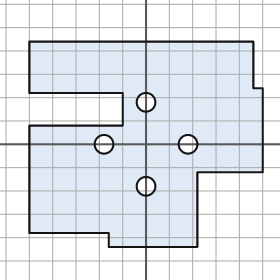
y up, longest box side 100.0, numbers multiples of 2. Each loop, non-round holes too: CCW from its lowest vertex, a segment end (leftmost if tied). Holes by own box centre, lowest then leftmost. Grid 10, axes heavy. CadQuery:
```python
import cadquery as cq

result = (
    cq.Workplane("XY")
    .moveTo(-16.0, -44.0)
    .lineTo(22.0, -44.0)
    .lineTo(22.0, -12.0)
    .lineTo(50.0, -12.0)
    .lineTo(50.0, 24.0)
    .lineTo(46.0, 24.0)
    .lineTo(46.0, 44.0)
    .lineTo(-50.0, 44.0)
    .lineTo(-50.0, 22.0)
    .lineTo(-10.0, 22.0)
    .lineTo(-10.0, 8.0)
    .lineTo(-50.0, 8.0)
    .lineTo(-50.0, -38.0)
    .lineTo(-16.0, -38.0)
    .close()
    .moveTo(0.0, -18.0)
    .circle(4.0)
    .moveTo(-18.0, 0.0)
    .circle(4.0)
    .moveTo(18.0, 0.0)
    .circle(4.0)
    .moveTo(0.0, 18.0)
    .circle(4.0)
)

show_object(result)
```